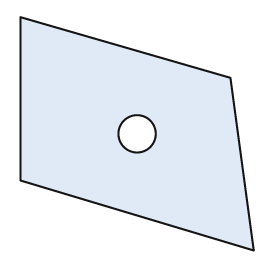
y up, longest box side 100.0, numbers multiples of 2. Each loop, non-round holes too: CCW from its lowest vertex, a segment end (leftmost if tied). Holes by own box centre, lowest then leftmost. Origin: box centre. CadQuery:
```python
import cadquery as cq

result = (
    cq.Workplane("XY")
    .moveTo(50.0, -50.0)
    .lineTo(40.0, 24.0)
    .lineTo(-50.0, 50.0)
    .lineTo(-50.0, -20.0)
    .close()
    .moveTo(0.0, 0.0)
    .circle(8.0)
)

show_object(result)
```